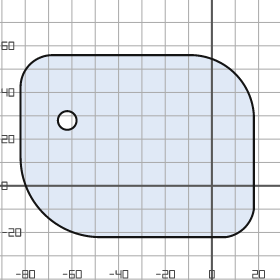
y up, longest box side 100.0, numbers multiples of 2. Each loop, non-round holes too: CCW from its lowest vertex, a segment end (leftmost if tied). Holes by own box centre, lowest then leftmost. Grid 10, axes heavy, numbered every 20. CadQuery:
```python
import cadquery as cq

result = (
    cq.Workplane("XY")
    .moveTo(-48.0, -22.0)
    .lineTo(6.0, -22.0)
    .threePointArc((14.0, -18.0), (18.0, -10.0))
    .lineTo(18.0, 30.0)
    .threePointArc((10.0, 48.0), (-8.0, 56.0))
    .lineTo(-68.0, 56.0)
    .threePointArc((-78.0, 52.0), (-82.0, 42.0))
    .lineTo(-82.0, 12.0)
    .threePointArc((-72.0, -12.0), (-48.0, -22.0))
    .close()
    .moveTo(-62.0, 28.0)
    .circle(4.0)
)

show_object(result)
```